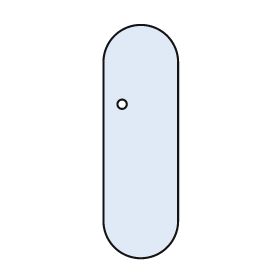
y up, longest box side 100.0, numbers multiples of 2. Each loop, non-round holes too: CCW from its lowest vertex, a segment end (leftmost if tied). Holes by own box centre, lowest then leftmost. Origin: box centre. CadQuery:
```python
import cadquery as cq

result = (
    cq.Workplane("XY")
    .moveTo(-16.0, -34.0)
    .threePointArc((0.0, -50.0), (16.0, -34.0))
    .lineTo(16.0, 34.0)
    .threePointArc((0.0, 50.0), (-16.0, 34.0))
    .close()
    .moveTo(-8.0, 16.0)
    .circle(2.0)
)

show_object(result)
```